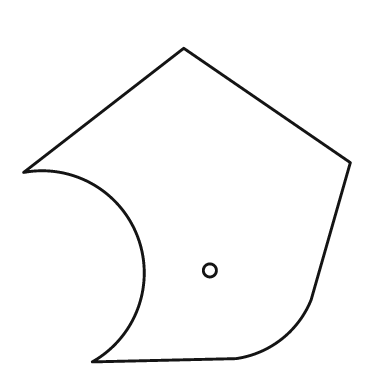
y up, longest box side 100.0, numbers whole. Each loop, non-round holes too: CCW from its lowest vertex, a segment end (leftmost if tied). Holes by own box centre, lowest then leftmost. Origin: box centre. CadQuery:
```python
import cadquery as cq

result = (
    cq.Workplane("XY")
    .moveTo(-29.0, -48.0)
    .lineTo(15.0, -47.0)
    .threePointArc((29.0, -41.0), (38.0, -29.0))
    .lineTo(50.0, 13.0)
    .lineTo(-1.0, 48.0)
    .lineTo(-50.0, 10.0)
    .threePointArc((-15.0, -10.0), (-29.0, -48.0))
    .close()
    .moveTo(7.0, -20.0)
    .circle(2.0)
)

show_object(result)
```